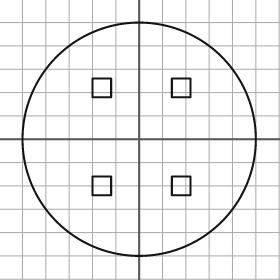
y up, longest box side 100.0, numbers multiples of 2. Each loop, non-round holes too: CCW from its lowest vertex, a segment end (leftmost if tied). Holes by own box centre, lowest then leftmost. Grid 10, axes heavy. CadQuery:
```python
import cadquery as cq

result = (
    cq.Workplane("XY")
    .moveTo(0.0, 0.0)
    .circle(50.0)
    .moveTo(-20.0, -24.0)
    .lineTo(-12.0, -24.0)
    .lineTo(-12.0, -16.0)
    .lineTo(-20.0, -16.0)
    .close()
    .moveTo(14.0, -24.0)
    .lineTo(22.0, -24.0)
    .lineTo(22.0, -16.0)
    .lineTo(14.0, -16.0)
    .close()
    .moveTo(-20.0, 18.0)
    .lineTo(-12.0, 18.0)
    .lineTo(-12.0, 26.0)
    .lineTo(-20.0, 26.0)
    .close()
    .moveTo(14.0, 18.0)
    .lineTo(22.0, 18.0)
    .lineTo(22.0, 26.0)
    .lineTo(14.0, 26.0)
    .close()
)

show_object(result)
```